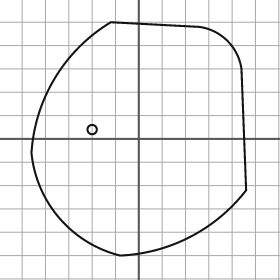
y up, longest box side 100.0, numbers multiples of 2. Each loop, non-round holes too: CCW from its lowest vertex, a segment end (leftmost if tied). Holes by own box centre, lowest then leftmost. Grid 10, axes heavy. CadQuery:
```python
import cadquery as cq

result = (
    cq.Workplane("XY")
    .moveTo(-8.0, -50.0)
    .threePointArc((22.0, -42.0), (46.0, -22.0))
    .lineTo(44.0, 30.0)
    .threePointArc((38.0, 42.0), (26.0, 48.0))
    .lineTo(-12.0, 50.0)
    .threePointArc((-36.0, 26.0), (-46.0, -6.0))
    .threePointArc((-34.0, -34.0), (-8.0, -50.0))
    .close()
    .moveTo(-20.0, 4.0)
    .circle(2.0)
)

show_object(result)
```